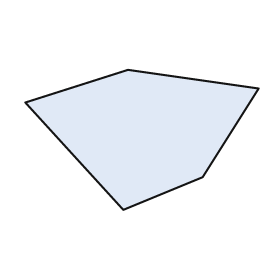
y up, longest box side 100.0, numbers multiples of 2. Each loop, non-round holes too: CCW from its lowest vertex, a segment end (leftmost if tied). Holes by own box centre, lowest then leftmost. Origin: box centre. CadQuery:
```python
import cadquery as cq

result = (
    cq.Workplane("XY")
    .moveTo(-8.0, -30.0)
    .lineTo(26.0, -16.0)
    .lineTo(50.0, 22.0)
    .lineTo(-6.0, 30.0)
    .lineTo(-50.0, 16.0)
    .close()
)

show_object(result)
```